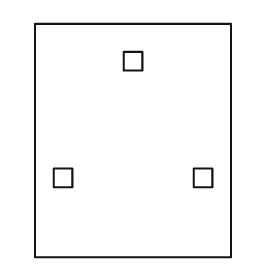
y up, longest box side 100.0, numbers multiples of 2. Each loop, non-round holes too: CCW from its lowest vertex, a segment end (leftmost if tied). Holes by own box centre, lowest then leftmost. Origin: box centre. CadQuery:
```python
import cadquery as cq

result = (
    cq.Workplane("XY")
    .moveTo(-42.0, -50.0)
    .lineTo(42.0, -50.0)
    .lineTo(42.0, 50.0)
    .lineTo(-42.0, 50.0)
    .close()
    .moveTo(-34.0, -20.0)
    .lineTo(-26.0, -20.0)
    .lineTo(-26.0, -12.0)
    .lineTo(-34.0, -12.0)
    .close()
    .moveTo(26.0, -20.0)
    .lineTo(34.0, -20.0)
    .lineTo(34.0, -12.0)
    .lineTo(26.0, -12.0)
    .close()
    .moveTo(-4.0, 30.0)
    .lineTo(4.0, 30.0)
    .lineTo(4.0, 38.0)
    .lineTo(-4.0, 38.0)
    .close()
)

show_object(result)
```